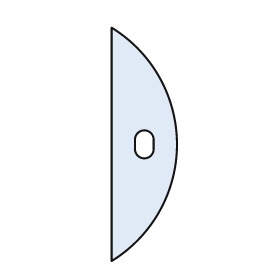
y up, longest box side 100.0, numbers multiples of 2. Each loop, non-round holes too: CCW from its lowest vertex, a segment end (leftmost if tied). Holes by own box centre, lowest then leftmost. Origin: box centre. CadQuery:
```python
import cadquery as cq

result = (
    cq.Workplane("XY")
    .moveTo(-14.0, -50.0)
    .threePointArc((14.0, 0.0), (-14.0, 50.0))
    .close()
    .moveTo(-4.0, -2.0)
    .threePointArc((0.0, -6.0), (4.0, -2.0))
    .lineTo(4.0, 2.0)
    .threePointArc((0.0, 6.0), (-4.0, 2.0))
    .close()
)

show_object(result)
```